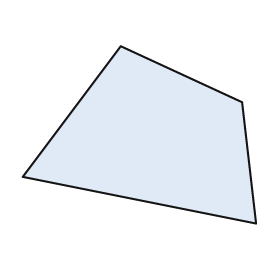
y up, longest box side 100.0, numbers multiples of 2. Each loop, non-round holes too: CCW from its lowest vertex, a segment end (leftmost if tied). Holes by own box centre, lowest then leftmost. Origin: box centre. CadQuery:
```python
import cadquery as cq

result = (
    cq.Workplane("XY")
    .moveTo(50.0, -38.0)
    .lineTo(44.0, 14.0)
    .lineTo(-8.0, 38.0)
    .lineTo(-50.0, -18.0)
    .close()
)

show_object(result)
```